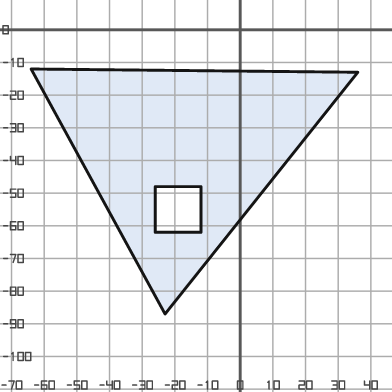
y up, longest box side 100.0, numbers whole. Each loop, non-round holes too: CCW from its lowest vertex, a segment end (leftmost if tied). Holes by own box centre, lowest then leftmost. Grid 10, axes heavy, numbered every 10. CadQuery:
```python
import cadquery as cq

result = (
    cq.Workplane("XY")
    .moveTo(-23.0, -87.0)
    .lineTo(36.0, -13.0)
    .lineTo(-64.0, -12.0)
    .close()
    .moveTo(-26.0, -62.0)
    .lineTo(-12.0, -62.0)
    .lineTo(-12.0, -48.0)
    .lineTo(-26.0, -48.0)
    .close()
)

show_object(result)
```